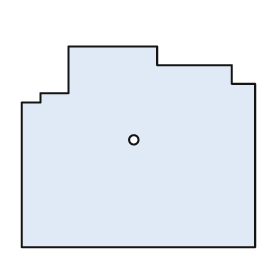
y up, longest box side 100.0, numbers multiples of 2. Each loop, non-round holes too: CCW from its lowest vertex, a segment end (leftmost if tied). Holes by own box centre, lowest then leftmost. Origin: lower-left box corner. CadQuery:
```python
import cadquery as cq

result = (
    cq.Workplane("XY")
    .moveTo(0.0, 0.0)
    .lineTo(100.0, 0.0)
    .lineTo(100.0, 70.0)
    .lineTo(90.0, 70.0)
    .lineTo(90.0, 78.0)
    .lineTo(58.0, 78.0)
    .lineTo(58.0, 86.0)
    .lineTo(20.0, 86.0)
    .lineTo(20.0, 66.0)
    .lineTo(8.0, 66.0)
    .lineTo(8.0, 62.0)
    .lineTo(0.0, 62.0)
    .close()
    .moveTo(48.0, 46.0)
    .circle(2.0)
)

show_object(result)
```